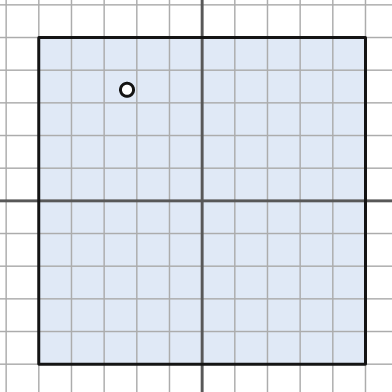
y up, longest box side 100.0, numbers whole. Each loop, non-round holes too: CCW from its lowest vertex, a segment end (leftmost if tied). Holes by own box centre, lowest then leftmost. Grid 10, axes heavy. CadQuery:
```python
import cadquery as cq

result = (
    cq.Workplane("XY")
    .moveTo(-50.0, -50.0)
    .lineTo(50.0, -50.0)
    .lineTo(50.0, 50.0)
    .lineTo(-50.0, 50.0)
    .close()
    .moveTo(-23.0, 34.0)
    .circle(2.0)
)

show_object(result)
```